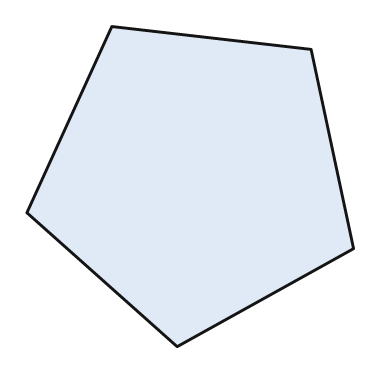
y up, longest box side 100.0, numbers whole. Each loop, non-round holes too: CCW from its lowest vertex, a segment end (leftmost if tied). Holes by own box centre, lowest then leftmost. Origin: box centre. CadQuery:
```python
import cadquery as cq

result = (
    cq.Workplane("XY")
    .moveTo(-4.0, -49.0)
    .lineTo(50.0, -19.0)
    .lineTo(37.0, 42.0)
    .lineTo(-24.0, 49.0)
    .lineTo(-50.0, -8.0)
    .close()
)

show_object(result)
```